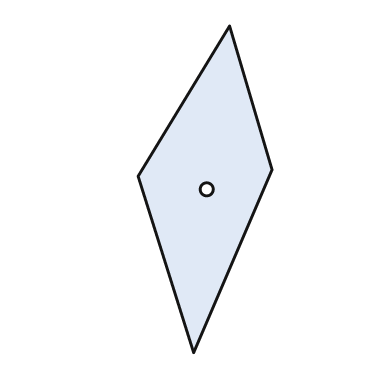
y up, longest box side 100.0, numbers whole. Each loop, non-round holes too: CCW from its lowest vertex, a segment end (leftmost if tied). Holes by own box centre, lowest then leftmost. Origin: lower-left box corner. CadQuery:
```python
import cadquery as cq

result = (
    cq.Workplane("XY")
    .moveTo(17.0, 0.0)
    .lineTo(41.0, 56.0)
    .lineTo(28.0, 100.0)
    .lineTo(0.0, 54.0)
    .close()
    .moveTo(21.0, 50.0)
    .circle(2.0)
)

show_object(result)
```